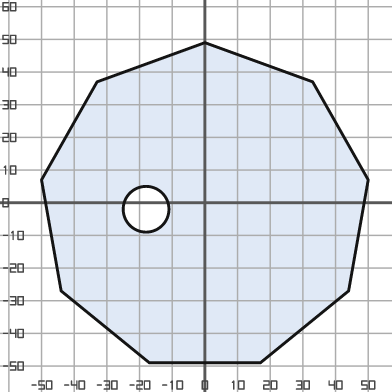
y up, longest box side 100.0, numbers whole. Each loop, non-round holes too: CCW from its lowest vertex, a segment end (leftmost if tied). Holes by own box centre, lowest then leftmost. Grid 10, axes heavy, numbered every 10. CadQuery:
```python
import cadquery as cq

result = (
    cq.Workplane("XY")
    .moveTo(-17.0, -49.0)
    .lineTo(17.0, -49.0)
    .lineTo(44.0, -27.0)
    .lineTo(50.0, 7.0)
    .lineTo(33.0, 37.0)
    .lineTo(0.0, 49.0)
    .lineTo(-33.0, 37.0)
    .lineTo(-50.0, 7.0)
    .lineTo(-44.0, -27.0)
    .close()
    .moveTo(-18.0, -2.0)
    .circle(7.0)
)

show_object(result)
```